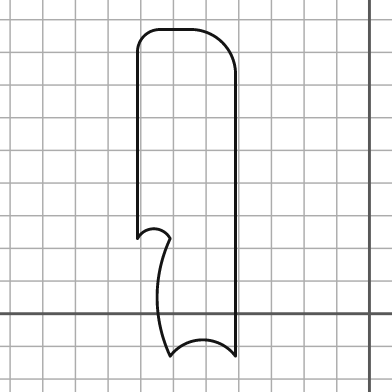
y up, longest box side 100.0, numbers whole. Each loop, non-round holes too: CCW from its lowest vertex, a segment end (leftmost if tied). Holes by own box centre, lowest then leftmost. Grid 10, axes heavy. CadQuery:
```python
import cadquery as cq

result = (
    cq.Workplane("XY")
    .moveTo(-61.0, -13.0)
    .threePointArc((-51.0, -8.0), (-41.0, -13.0))
    .lineTo(-41.0, 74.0)
    .threePointArc((-45.0, 83.0), (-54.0, 87.0))
    .lineTo(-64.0, 87.0)
    .threePointArc((-69.0, 85.0), (-71.0, 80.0))
    .lineTo(-71.0, 23.0)
    .threePointArc((-66.0, 26.0), (-61.0, 23.0))
    .threePointArc((-65.0, 5.0), (-61.0, -13.0))
    .close()
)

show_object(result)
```